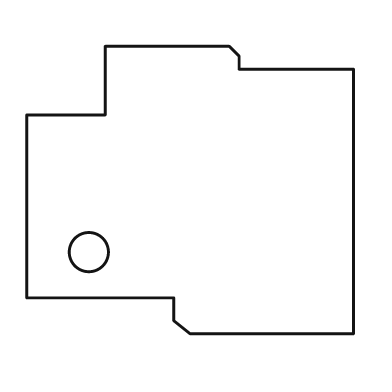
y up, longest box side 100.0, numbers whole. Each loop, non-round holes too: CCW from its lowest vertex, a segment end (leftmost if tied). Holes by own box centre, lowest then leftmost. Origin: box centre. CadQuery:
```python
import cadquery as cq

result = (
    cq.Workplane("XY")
    .moveTo(0.0, -44.0)
    .lineTo(50.0, -44.0)
    .lineTo(50.0, 37.0)
    .lineTo(15.0, 37.0)
    .lineTo(15.0, 41.0)
    .lineTo(12.0, 44.0)
    .lineTo(-26.0, 44.0)
    .lineTo(-26.0, 23.0)
    .lineTo(-50.0, 23.0)
    .lineTo(-50.0, -33.0)
    .lineTo(-5.0, -33.0)
    .lineTo(-5.0, -40.0)
    .close()
    .moveTo(-31.0, -19.0)
    .circle(6.0)
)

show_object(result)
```